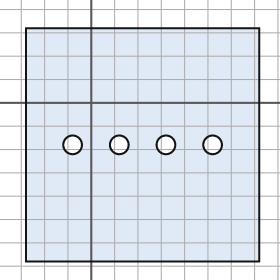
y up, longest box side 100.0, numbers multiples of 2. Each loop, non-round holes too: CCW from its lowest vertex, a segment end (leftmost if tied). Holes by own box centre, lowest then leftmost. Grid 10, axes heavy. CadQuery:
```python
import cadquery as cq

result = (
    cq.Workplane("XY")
    .moveTo(-28.0, -68.0)
    .lineTo(72.0, -68.0)
    .lineTo(72.0, 32.0)
    .lineTo(-28.0, 32.0)
    .close()
    .moveTo(-8.0, -18.0)
    .circle(4.0)
    .moveTo(12.0, -18.0)
    .circle(4.0)
    .moveTo(32.0, -18.0)
    .circle(4.0)
    .moveTo(52.0, -18.0)
    .circle(4.0)
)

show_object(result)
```